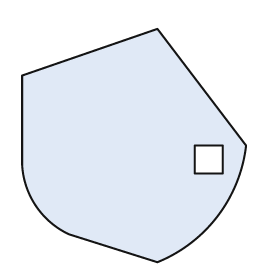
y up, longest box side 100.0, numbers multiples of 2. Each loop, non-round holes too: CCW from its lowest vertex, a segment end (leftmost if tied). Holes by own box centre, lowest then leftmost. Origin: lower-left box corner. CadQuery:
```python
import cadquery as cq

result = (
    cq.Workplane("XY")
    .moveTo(58.0, 0.0)
    .threePointArc((84.0, 20.0), (96.0, 50.0))
    .lineTo(58.0, 100.0)
    .lineTo(0.0, 80.0)
    .lineTo(0.0, 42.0)
    .threePointArc((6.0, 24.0), (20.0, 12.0))
    .close()
    .moveTo(74.0, 38.0)
    .lineTo(86.0, 38.0)
    .lineTo(86.0, 50.0)
    .lineTo(74.0, 50.0)
    .close()
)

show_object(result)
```